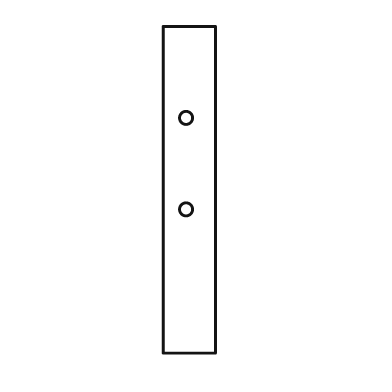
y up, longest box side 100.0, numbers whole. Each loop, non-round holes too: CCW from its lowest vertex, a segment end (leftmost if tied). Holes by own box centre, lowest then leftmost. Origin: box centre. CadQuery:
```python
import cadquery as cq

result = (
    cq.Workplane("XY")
    .moveTo(-8.0, -50.0)
    .lineTo(8.0, -50.0)
    .lineTo(8.0, 50.0)
    .lineTo(-8.0, 50.0)
    .close()
    .moveTo(-1.0, -6.0)
    .circle(2.0)
    .moveTo(-1.0, 22.0)
    .circle(2.0)
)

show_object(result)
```